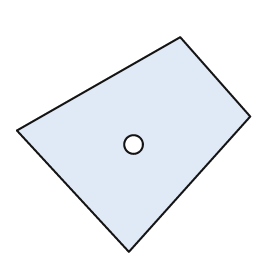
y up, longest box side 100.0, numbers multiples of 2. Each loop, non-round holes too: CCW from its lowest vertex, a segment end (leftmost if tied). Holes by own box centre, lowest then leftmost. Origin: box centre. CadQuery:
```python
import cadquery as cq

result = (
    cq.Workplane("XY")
    .moveTo(-2.0, -46.0)
    .lineTo(50.0, 12.0)
    .lineTo(20.0, 46.0)
    .lineTo(-50.0, 6.0)
    .close()
    .moveTo(0.0, 0.0)
    .circle(4.0)
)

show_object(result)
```